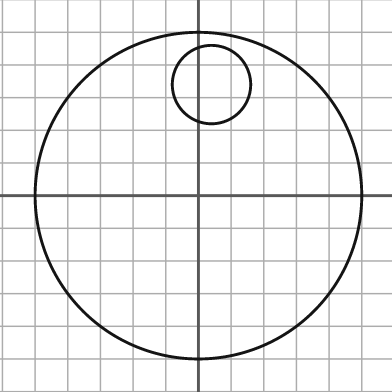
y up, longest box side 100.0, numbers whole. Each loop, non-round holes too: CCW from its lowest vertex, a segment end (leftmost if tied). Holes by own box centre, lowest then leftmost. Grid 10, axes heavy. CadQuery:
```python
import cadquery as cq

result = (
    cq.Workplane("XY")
    .moveTo(0.0, 0.0)
    .circle(50.0)
    .moveTo(4.0, 34.0)
    .circle(12.0)
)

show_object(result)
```